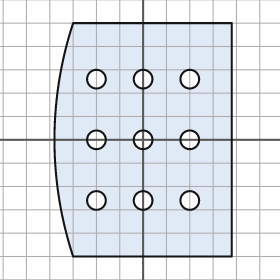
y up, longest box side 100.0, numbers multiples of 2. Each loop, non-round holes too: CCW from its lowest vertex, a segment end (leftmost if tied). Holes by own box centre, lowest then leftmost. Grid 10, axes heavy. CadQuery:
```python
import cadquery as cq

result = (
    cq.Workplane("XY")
    .moveTo(-30.0, -50.0)
    .lineTo(38.0, -50.0)
    .lineTo(38.0, 50.0)
    .lineTo(-30.0, 50.0)
    .threePointArc((-38.0, 0.0), (-30.0, -50.0))
    .close()
    .moveTo(-20.0, -26.0)
    .circle(4.0)
    .moveTo(0.0, -26.0)
    .circle(4.0)
    .moveTo(20.0, -26.0)
    .circle(4.0)
    .moveTo(-20.0, 0.0)
    .circle(4.0)
    .moveTo(0.0, 0.0)
    .circle(4.0)
    .moveTo(20.0, 0.0)
    .circle(4.0)
    .moveTo(-20.0, 26.0)
    .circle(4.0)
    .moveTo(0.0, 26.0)
    .circle(4.0)
    .moveTo(20.0, 26.0)
    .circle(4.0)
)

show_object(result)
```